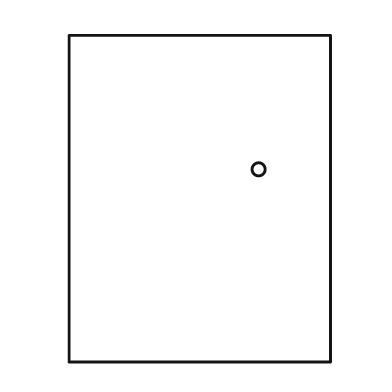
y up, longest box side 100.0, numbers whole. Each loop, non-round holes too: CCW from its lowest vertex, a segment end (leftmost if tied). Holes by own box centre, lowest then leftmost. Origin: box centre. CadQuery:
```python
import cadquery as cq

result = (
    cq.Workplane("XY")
    .moveTo(-40.0, -50.0)
    .lineTo(40.0, -50.0)
    .lineTo(40.0, 50.0)
    .lineTo(-40.0, 50.0)
    .close()
    .moveTo(18.0, 9.0)
    .circle(2.0)
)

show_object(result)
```